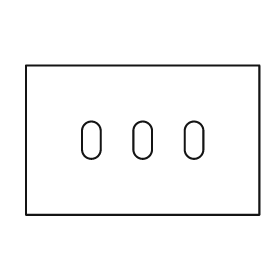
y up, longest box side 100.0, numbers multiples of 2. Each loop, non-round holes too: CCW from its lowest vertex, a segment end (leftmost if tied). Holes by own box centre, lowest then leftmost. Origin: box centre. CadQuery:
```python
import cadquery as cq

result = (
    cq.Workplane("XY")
    .moveTo(-50.0, -32.0)
    .lineTo(50.0, -32.0)
    .lineTo(50.0, 32.0)
    .lineTo(-50.0, 32.0)
    .close()
    .moveTo(-26.0, -4.0)
    .threePointArc((-22.0, -8.0), (-18.0, -4.0))
    .lineTo(-18.0, 4.0)
    .threePointArc((-22.0, 8.0), (-26.0, 4.0))
    .close()
    .moveTo(-4.0, -4.0)
    .threePointArc((0.0, -8.0), (4.0, -4.0))
    .lineTo(4.0, 4.0)
    .threePointArc((0.0, 8.0), (-4.0, 4.0))
    .close()
    .moveTo(18.0, -4.0)
    .threePointArc((22.0, -8.0), (26.0, -4.0))
    .lineTo(26.0, 4.0)
    .threePointArc((22.0, 8.0), (18.0, 4.0))
    .close()
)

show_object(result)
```